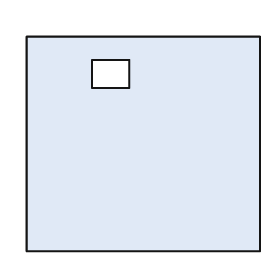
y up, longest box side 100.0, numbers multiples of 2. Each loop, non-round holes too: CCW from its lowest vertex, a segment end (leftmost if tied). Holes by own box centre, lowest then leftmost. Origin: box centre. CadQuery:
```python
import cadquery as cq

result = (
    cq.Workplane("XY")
    .moveTo(-50.0, -46.0)
    .lineTo(50.0, -46.0)
    .lineTo(50.0, 46.0)
    .lineTo(-50.0, 46.0)
    .close()
    .moveTo(-22.0, 24.0)
    .lineTo(-6.0, 24.0)
    .lineTo(-6.0, 36.0)
    .lineTo(-22.0, 36.0)
    .close()
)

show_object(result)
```